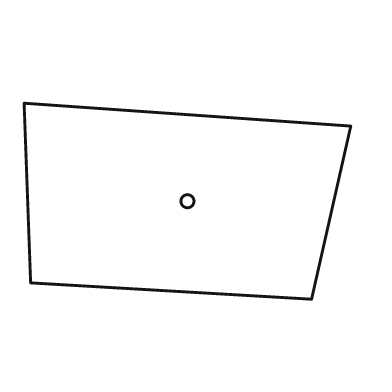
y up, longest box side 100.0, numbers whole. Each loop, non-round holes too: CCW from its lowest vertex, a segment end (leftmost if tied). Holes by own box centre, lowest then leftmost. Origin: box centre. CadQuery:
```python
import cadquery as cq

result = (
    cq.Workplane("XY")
    .moveTo(38.0, -30.0)
    .lineTo(50.0, 23.0)
    .lineTo(-50.0, 30.0)
    .lineTo(-48.0, -25.0)
    .close()
    .moveTo(0.0, 0.0)
    .circle(2.0)
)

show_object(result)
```